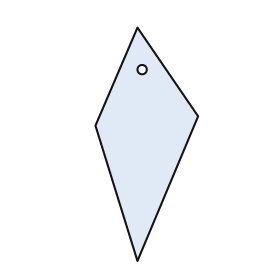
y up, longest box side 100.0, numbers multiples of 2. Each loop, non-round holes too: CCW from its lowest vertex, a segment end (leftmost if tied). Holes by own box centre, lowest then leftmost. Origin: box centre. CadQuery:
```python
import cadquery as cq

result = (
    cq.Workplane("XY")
    .moveTo(-4.0, -50.0)
    .lineTo(22.0, 12.0)
    .lineTo(-4.0, 50.0)
    .lineTo(-22.0, 8.0)
    .close()
    .moveTo(-2.0, 32.0)
    .circle(2.0)
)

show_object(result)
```